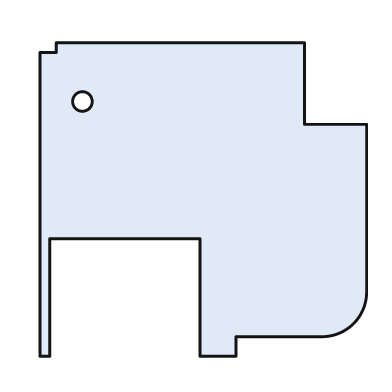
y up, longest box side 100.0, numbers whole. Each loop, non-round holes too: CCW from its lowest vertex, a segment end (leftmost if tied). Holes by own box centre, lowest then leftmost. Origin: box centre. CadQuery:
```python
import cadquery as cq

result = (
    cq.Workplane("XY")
    .moveTo(-50.0, -48.0)
    .lineTo(-47.0, -48.0)
    .lineTo(-47.0, -12.0)
    .lineTo(-1.0, -12.0)
    .lineTo(-1.0, -48.0)
    .lineTo(10.0, -48.0)
    .lineTo(10.0, -42.0)
    .lineTo(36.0, -42.0)
    .threePointArc((46.0, -38.0), (50.0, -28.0))
    .lineTo(50.0, 23.0)
    .lineTo(31.0, 23.0)
    .lineTo(31.0, 48.0)
    .lineTo(-45.0, 48.0)
    .lineTo(-45.0, 45.0)
    .lineTo(-50.0, 45.0)
    .close()
    .moveTo(-37.0, 30.0)
    .circle(3.0)
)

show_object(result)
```